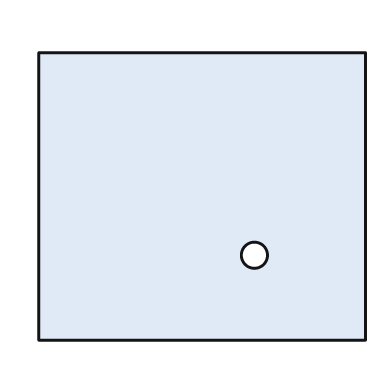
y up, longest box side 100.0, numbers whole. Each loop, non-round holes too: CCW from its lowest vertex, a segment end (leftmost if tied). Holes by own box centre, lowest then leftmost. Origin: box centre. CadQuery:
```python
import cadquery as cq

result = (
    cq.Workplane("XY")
    .moveTo(-50.0, -44.0)
    .lineTo(50.0, -44.0)
    .lineTo(50.0, 44.0)
    .lineTo(-50.0, 44.0)
    .close()
    .moveTo(16.0, -18.0)
    .circle(4.0)
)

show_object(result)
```